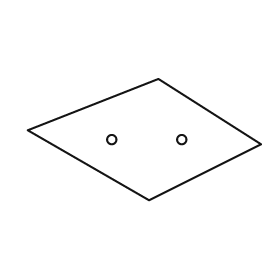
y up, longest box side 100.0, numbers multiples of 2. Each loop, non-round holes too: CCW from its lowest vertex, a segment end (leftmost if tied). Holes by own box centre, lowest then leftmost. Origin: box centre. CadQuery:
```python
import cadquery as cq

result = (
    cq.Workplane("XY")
    .moveTo(2.0, -26.0)
    .lineTo(50.0, -2.0)
    .lineTo(6.0, 26.0)
    .lineTo(-50.0, 4.0)
    .close()
    .moveTo(-14.0, 0.0)
    .circle(2.0)
    .moveTo(16.0, 0.0)
    .circle(2.0)
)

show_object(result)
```